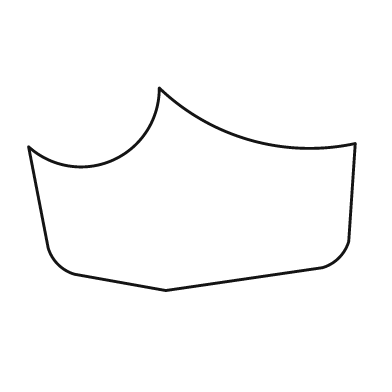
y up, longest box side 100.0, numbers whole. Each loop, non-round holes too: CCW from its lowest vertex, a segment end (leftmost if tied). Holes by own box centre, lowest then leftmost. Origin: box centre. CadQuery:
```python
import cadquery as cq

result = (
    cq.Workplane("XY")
    .moveTo(-8.0, -31.0)
    .lineTo(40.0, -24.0)
    .threePointArc((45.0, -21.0), (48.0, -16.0))
    .lineTo(50.0, 14.0)
    .threePointArc((18.0, 15.0), (-10.0, 31.0))
    .threePointArc((-24.0, 9.0), (-50.0, 13.0))
    .lineTo(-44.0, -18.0)
    .threePointArc((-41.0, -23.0), (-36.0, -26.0))
    .close()
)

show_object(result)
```